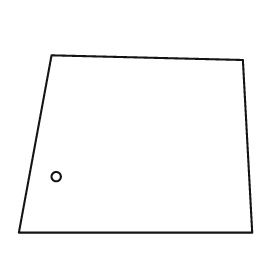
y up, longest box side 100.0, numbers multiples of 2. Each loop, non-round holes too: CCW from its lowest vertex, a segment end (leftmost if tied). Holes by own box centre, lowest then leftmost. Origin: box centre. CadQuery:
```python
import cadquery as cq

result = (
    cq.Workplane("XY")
    .moveTo(-50.0, -38.0)
    .lineTo(50.0, -38.0)
    .lineTo(46.0, 36.0)
    .lineTo(-36.0, 38.0)
    .close()
    .moveTo(-34.0, -14.0)
    .circle(2.0)
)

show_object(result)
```